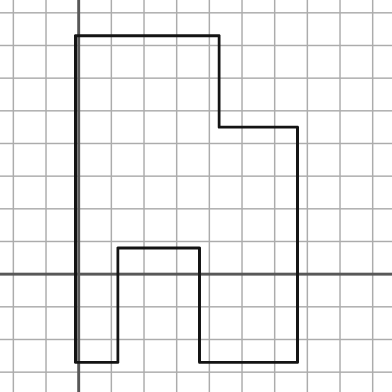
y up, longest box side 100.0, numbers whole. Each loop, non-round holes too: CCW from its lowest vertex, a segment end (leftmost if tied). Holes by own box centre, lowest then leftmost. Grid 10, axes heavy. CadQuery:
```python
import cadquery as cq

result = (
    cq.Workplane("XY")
    .moveTo(-1.0, -27.0)
    .lineTo(12.0, -27.0)
    .lineTo(12.0, 8.0)
    .lineTo(37.0, 8.0)
    .lineTo(37.0, -27.0)
    .lineTo(67.0, -27.0)
    .lineTo(67.0, 45.0)
    .lineTo(43.0, 45.0)
    .lineTo(43.0, 73.0)
    .lineTo(-1.0, 73.0)
    .close()
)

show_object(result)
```